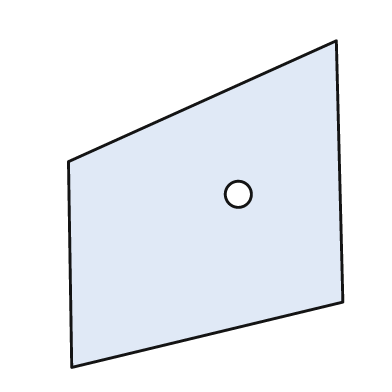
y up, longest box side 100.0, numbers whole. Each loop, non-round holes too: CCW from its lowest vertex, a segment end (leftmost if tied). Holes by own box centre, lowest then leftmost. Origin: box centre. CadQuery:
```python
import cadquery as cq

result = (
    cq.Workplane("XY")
    .moveTo(-41.0, -50.0)
    .lineTo(42.0, -30.0)
    .lineTo(40.0, 50.0)
    .lineTo(-42.0, 13.0)
    .close()
    .moveTo(10.0, 3.0)
    .circle(4.0)
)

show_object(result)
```